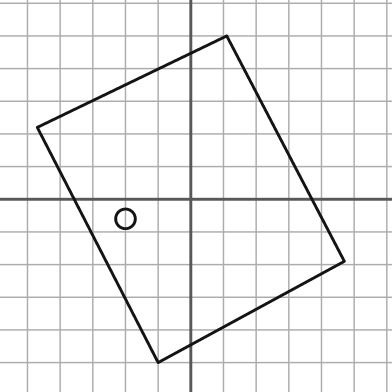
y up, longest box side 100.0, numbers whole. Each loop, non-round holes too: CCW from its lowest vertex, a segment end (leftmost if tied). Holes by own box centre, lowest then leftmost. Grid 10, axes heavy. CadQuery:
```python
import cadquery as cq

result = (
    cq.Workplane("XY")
    .moveTo(-10.0, -50.0)
    .lineTo(47.0, -19.0)
    .lineTo(11.0, 50.0)
    .lineTo(-47.0, 22.0)
    .close()
    .moveTo(-20.0, -6.0)
    .circle(3.0)
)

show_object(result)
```